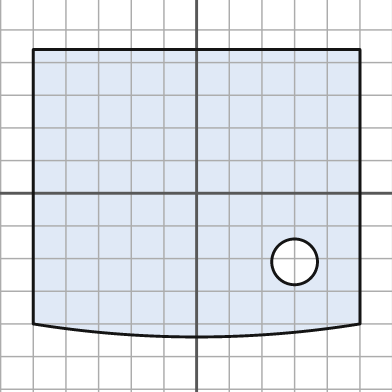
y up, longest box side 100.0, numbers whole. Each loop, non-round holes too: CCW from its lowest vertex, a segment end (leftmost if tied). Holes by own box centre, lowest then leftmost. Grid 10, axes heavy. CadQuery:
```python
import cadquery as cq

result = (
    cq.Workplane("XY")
    .moveTo(-50.0, -40.0)
    .threePointArc((0.0, -44.0), (50.0, -40.0))
    .lineTo(50.0, 44.0)
    .lineTo(-50.0, 44.0)
    .close()
    .moveTo(30.0, -21.0)
    .circle(7.0)
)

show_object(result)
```